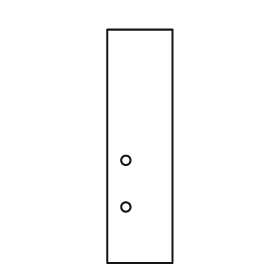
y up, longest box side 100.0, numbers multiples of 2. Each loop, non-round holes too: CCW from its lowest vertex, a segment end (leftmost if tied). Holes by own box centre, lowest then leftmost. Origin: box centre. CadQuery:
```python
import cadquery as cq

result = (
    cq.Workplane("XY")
    .moveTo(-14.0, -50.0)
    .lineTo(14.0, -50.0)
    .lineTo(14.0, 50.0)
    .lineTo(-14.0, 50.0)
    .close()
    .moveTo(-6.0, -26.0)
    .circle(2.0)
    .moveTo(-6.0, -6.0)
    .circle(2.0)
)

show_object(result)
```